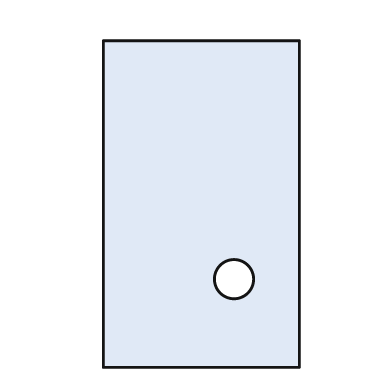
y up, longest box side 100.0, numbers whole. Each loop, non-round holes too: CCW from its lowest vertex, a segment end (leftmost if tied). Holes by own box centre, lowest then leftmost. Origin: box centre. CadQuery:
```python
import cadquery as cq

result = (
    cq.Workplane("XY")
    .moveTo(-30.0, -50.0)
    .lineTo(30.0, -50.0)
    .lineTo(30.0, 50.0)
    .lineTo(-30.0, 50.0)
    .close()
    .moveTo(10.0, -23.0)
    .circle(6.0)
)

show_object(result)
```